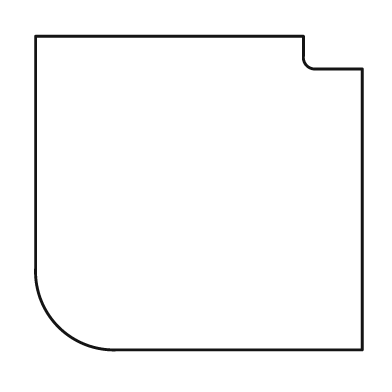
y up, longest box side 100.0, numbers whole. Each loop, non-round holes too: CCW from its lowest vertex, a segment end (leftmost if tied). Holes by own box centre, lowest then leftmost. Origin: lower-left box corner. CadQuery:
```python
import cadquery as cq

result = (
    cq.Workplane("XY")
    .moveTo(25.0, 0.0)
    .lineTo(100.0, 0.0)
    .lineTo(100.0, 86.0)
    .lineTo(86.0, 86.0)
    .threePointArc((83.0, 87.0), (82.0, 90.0))
    .lineTo(82.0, 96.0)
    .lineTo(0.0, 96.0)
    .lineTo(0.0, 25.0)
    .threePointArc((7.0, 7.0), (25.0, 0.0))
    .close()
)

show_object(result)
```